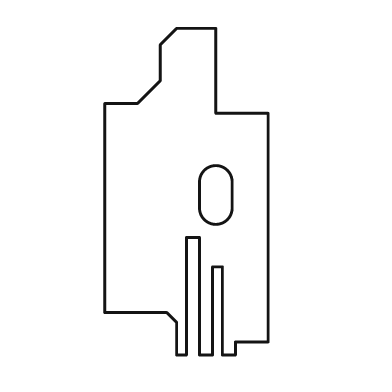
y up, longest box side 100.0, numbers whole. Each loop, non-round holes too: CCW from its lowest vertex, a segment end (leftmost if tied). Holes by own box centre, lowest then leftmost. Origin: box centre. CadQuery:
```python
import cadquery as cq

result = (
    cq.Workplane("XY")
    .moveTo(-3.0, -50.0)
    .lineTo(0.0, -50.0)
    .lineTo(0.0, -14.0)
    .lineTo(4.0, -14.0)
    .lineTo(4.0, -50.0)
    .lineTo(8.0, -50.0)
    .lineTo(8.0, -23.0)
    .lineTo(11.0, -23.0)
    .lineTo(11.0, -50.0)
    .lineTo(15.0, -50.0)
    .lineTo(15.0, -46.0)
    .lineTo(25.0, -46.0)
    .lineTo(25.0, 24.0)
    .lineTo(9.0, 24.0)
    .lineTo(9.0, 50.0)
    .lineTo(-3.0, 50.0)
    .lineTo(-8.0, 45.0)
    .lineTo(-8.0, 34.0)
    .lineTo(-15.0, 27.0)
    .lineTo(-25.0, 27.0)
    .lineTo(-25.0, -37.0)
    .lineTo(-6.0, -37.0)
    .lineTo(-3.0, -40.0)
    .close()
    .moveTo(4.0, -5.0)
    .threePointArc((9.0, -10.0), (14.0, -5.0))
    .lineTo(14.0, 3.0)
    .threePointArc((9.0, 8.0), (4.0, 3.0))
    .close()
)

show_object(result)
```